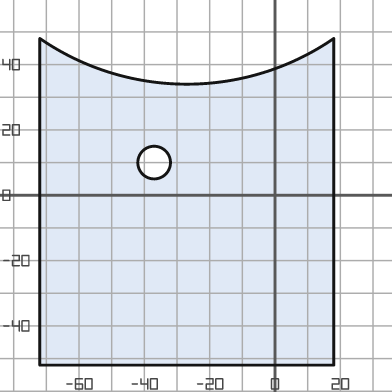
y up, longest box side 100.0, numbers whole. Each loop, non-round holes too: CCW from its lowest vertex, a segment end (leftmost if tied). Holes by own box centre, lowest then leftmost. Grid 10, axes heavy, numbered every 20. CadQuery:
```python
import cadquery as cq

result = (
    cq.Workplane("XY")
    .moveTo(-72.0, -52.0)
    .lineTo(18.0, -52.0)
    .lineTo(18.0, 48.0)
    .threePointArc((-27.0, 34.0), (-72.0, 48.0))
    .close()
    .moveTo(-37.0, 10.0)
    .circle(5.0)
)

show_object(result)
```